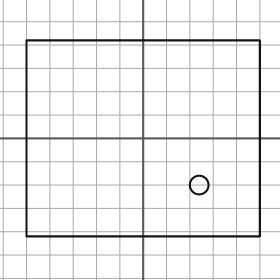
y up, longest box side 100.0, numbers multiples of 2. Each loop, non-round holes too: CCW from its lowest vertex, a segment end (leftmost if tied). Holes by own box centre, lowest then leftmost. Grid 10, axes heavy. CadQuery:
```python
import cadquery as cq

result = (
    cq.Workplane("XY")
    .moveTo(-50.0, -42.0)
    .lineTo(50.0, -42.0)
    .lineTo(50.0, 42.0)
    .lineTo(-50.0, 42.0)
    .close()
    .moveTo(24.0, -20.0)
    .circle(4.0)
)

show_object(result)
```